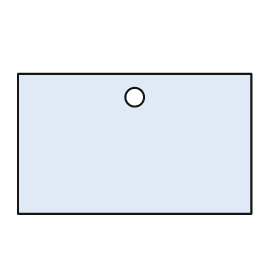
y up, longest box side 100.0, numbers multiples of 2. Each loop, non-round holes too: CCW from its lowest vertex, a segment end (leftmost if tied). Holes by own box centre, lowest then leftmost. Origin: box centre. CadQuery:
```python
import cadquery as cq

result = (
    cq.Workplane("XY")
    .moveTo(-50.0, -30.0)
    .lineTo(50.0, -30.0)
    .lineTo(50.0, 30.0)
    .lineTo(-50.0, 30.0)
    .close()
    .moveTo(0.0, 20.0)
    .circle(4.0)
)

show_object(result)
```